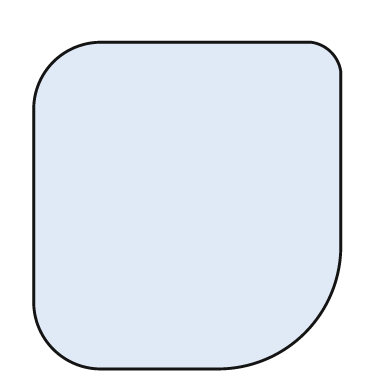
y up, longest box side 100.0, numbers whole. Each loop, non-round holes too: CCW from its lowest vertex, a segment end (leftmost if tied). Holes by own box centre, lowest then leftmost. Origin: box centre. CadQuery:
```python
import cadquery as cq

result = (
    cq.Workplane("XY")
    .moveTo(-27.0, -50.0)
    .lineTo(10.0, -50.0)
    .threePointArc((36.0, -39.0), (47.0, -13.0))
    .lineTo(47.0, 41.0)
    .threePointArc((44.0, 47.0), (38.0, 50.0))
    .lineTo(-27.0, 50.0)
    .threePointArc((-41.0, 44.0), (-47.0, 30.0))
    .lineTo(-47.0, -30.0)
    .threePointArc((-41.0, -44.0), (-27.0, -50.0))
    .close()
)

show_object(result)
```